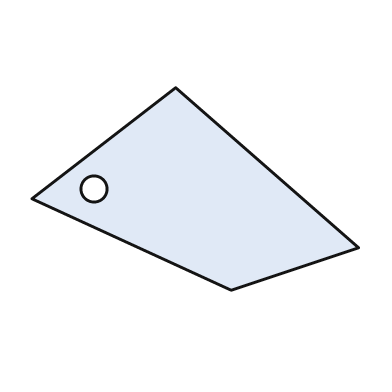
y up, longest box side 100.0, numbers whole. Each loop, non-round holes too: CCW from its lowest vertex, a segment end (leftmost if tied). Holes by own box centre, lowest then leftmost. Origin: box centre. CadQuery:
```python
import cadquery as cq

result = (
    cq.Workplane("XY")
    .moveTo(11.0, -31.0)
    .lineTo(50.0, -18.0)
    .lineTo(-6.0, 31.0)
    .lineTo(-50.0, -3.0)
    .close()
    .moveTo(-31.0, 0.0)
    .circle(4.0)
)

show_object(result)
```